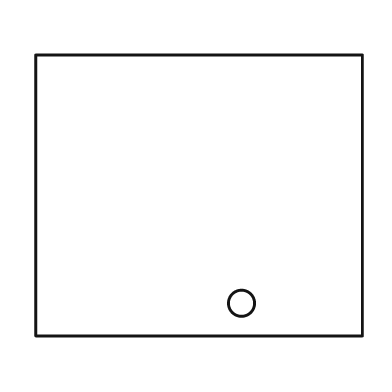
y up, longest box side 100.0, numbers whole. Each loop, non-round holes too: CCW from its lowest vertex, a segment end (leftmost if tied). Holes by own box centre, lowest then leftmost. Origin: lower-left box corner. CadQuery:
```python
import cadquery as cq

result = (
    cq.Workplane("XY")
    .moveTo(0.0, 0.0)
    .lineTo(100.0, 0.0)
    .lineTo(100.0, 86.0)
    .lineTo(0.0, 86.0)
    .close()
    .moveTo(63.0, 10.0)
    .circle(4.0)
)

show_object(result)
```